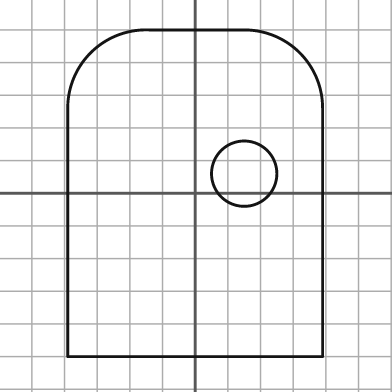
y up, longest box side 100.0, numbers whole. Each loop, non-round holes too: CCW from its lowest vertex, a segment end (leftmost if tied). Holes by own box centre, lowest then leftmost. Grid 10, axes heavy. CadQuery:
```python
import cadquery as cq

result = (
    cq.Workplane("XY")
    .moveTo(-39.0, -50.0)
    .lineTo(39.0, -50.0)
    .lineTo(39.0, 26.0)
    .threePointArc((32.0, 43.0), (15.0, 50.0))
    .lineTo(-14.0, 50.0)
    .threePointArc((-32.0, 43.0), (-39.0, 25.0))
    .close()
    .moveTo(15.0, 6.0)
    .circle(10.0)
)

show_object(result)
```